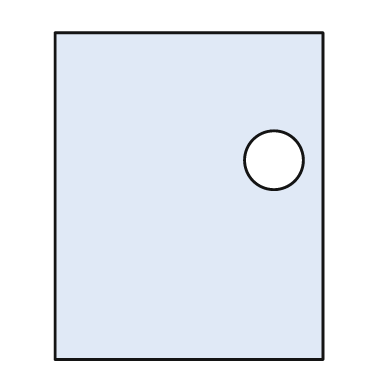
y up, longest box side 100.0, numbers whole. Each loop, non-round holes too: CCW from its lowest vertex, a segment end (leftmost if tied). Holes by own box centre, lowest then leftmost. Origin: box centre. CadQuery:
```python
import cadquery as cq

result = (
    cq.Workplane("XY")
    .moveTo(-41.0, -50.0)
    .lineTo(41.0, -50.0)
    .lineTo(41.0, 50.0)
    .lineTo(-41.0, 50.0)
    .close()
    .moveTo(26.0, 11.0)
    .circle(9.0)
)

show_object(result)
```